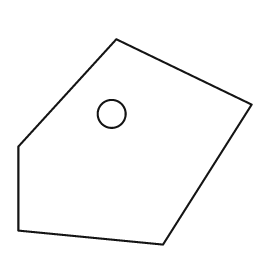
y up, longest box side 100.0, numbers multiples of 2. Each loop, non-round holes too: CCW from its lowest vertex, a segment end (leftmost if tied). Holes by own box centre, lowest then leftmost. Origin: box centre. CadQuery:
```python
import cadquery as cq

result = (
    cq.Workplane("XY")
    .moveTo(12.0, -44.0)
    .lineTo(50.0, 16.0)
    .lineTo(-8.0, 44.0)
    .lineTo(-50.0, -2.0)
    .lineTo(-50.0, -38.0)
    .close()
    .moveTo(-10.0, 12.0)
    .circle(6.0)
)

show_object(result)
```